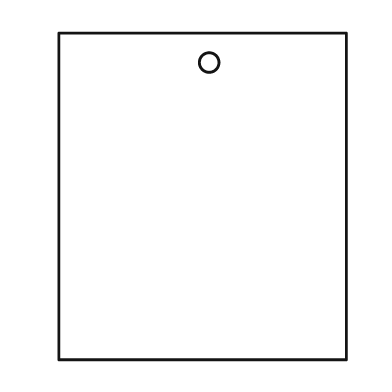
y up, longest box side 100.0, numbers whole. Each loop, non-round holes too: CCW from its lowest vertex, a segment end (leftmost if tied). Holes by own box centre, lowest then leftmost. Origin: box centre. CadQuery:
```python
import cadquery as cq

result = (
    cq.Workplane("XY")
    .moveTo(-44.0, -50.0)
    .lineTo(44.0, -50.0)
    .lineTo(44.0, 50.0)
    .lineTo(-44.0, 50.0)
    .close()
    .moveTo(2.0, 41.0)
    .circle(3.0)
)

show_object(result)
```